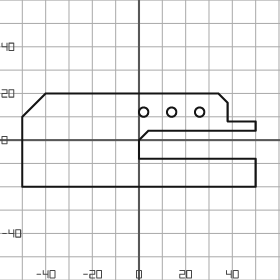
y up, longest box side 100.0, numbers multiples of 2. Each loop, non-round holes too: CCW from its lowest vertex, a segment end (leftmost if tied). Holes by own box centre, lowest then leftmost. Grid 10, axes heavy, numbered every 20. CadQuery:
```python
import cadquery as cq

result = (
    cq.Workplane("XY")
    .moveTo(-50.0, -20.0)
    .lineTo(50.0, -20.0)
    .lineTo(50.0, -8.0)
    .lineTo(0.0, -8.0)
    .lineTo(0.0, 0.0)
    .lineTo(4.0, 4.0)
    .lineTo(50.0, 4.0)
    .lineTo(50.0, 8.0)
    .lineTo(38.0, 8.0)
    .lineTo(38.0, 16.0)
    .lineTo(34.0, 20.0)
    .lineTo(-40.0, 20.0)
    .lineTo(-50.0, 10.0)
    .close()
    .moveTo(2.0, 12.0)
    .circle(2.0)
    .moveTo(14.0, 12.0)
    .circle(2.0)
    .moveTo(26.0, 12.0)
    .circle(2.0)
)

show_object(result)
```